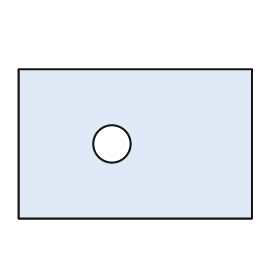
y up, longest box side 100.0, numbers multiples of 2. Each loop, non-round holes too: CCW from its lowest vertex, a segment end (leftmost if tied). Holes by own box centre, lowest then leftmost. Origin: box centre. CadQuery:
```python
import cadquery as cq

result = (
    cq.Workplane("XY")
    .moveTo(-50.0, -32.0)
    .lineTo(50.0, -32.0)
    .lineTo(50.0, 32.0)
    .lineTo(-50.0, 32.0)
    .close()
    .moveTo(-10.0, 0.0)
    .circle(8.0)
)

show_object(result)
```